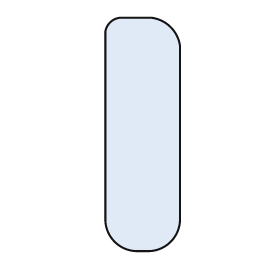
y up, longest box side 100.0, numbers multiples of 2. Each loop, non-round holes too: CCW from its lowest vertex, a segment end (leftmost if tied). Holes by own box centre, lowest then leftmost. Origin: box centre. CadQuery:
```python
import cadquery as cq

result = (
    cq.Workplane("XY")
    .moveTo(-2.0, -50.0)
    .lineTo(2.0, -50.0)
    .threePointArc((12.0, -46.0), (16.0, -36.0))
    .lineTo(16.0, 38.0)
    .threePointArc((12.0, 46.0), (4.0, 50.0))
    .lineTo(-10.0, 50.0)
    .threePointArc((-14.0, 48.0), (-16.0, 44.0))
    .lineTo(-16.0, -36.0)
    .threePointArc((-12.0, -46.0), (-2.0, -50.0))
    .close()
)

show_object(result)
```